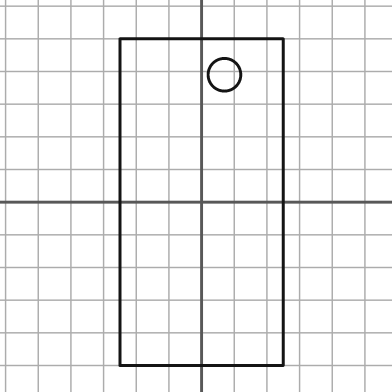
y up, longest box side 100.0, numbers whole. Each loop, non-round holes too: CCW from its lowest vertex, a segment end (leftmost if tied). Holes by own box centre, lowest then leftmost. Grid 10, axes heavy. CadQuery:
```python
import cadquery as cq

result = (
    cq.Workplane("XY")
    .moveTo(-25.0, -50.0)
    .lineTo(25.0, -50.0)
    .lineTo(25.0, 50.0)
    .lineTo(-25.0, 50.0)
    .close()
    .moveTo(7.0, 39.0)
    .circle(5.0)
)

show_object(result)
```